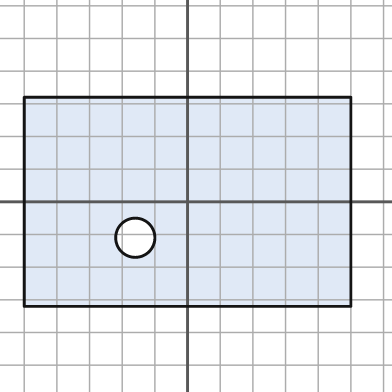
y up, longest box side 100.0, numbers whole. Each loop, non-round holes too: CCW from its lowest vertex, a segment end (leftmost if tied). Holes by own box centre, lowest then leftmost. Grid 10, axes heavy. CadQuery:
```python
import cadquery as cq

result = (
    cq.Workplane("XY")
    .moveTo(-50.0, -32.0)
    .lineTo(50.0, -32.0)
    .lineTo(50.0, 32.0)
    .lineTo(-50.0, 32.0)
    .close()
    .moveTo(-16.0, -11.0)
    .circle(6.0)
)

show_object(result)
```